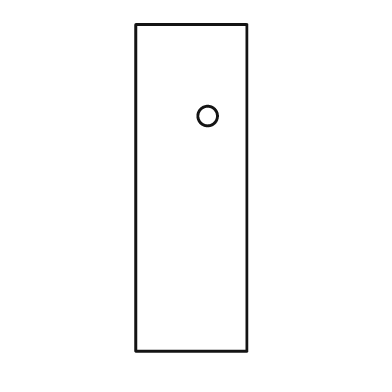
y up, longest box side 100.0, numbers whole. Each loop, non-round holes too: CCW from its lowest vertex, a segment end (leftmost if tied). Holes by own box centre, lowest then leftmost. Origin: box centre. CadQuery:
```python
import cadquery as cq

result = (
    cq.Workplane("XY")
    .moveTo(-17.0, -50.0)
    .lineTo(17.0, -50.0)
    .lineTo(17.0, 50.0)
    .lineTo(-17.0, 50.0)
    .close()
    .moveTo(5.0, 22.0)
    .circle(3.0)
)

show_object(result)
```